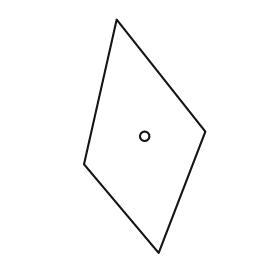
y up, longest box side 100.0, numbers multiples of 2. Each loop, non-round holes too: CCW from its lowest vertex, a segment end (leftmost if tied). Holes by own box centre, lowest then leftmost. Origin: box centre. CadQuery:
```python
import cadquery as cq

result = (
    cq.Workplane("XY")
    .moveTo(6.0, -50.0)
    .lineTo(26.0, 2.0)
    .lineTo(-12.0, 50.0)
    .lineTo(-26.0, -12.0)
    .close()
    .moveTo(0.0, 0.0)
    .circle(2.0)
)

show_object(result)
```